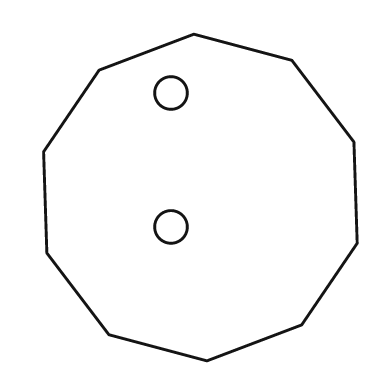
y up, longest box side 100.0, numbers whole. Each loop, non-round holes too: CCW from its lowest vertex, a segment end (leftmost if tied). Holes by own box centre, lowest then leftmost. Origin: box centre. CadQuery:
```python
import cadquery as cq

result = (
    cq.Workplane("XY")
    .moveTo(2.0, -50.0)
    .lineTo(31.0, -39.0)
    .lineTo(48.0, -14.0)
    .lineTo(47.0, 17.0)
    .lineTo(28.0, 42.0)
    .lineTo(-2.0, 50.0)
    .lineTo(-31.0, 39.0)
    .lineTo(-48.0, 14.0)
    .lineTo(-47.0, -17.0)
    .lineTo(-28.0, -42.0)
    .close()
    .moveTo(-9.0, -9.0)
    .circle(5.0)
    .moveTo(-9.0, 32.0)
    .circle(5.0)
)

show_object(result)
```